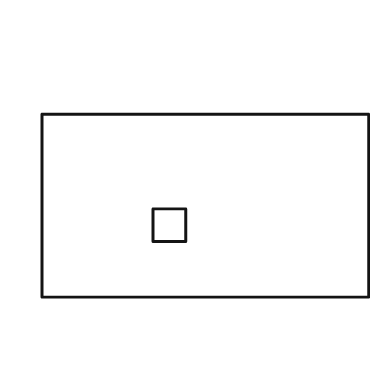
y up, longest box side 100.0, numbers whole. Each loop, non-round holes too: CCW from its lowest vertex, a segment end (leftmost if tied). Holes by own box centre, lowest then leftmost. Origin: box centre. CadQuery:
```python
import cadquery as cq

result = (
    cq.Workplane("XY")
    .moveTo(-50.0, -28.0)
    .lineTo(50.0, -28.0)
    .lineTo(50.0, 28.0)
    .lineTo(-50.0, 28.0)
    .close()
    .moveTo(-16.0, -11.0)
    .lineTo(-6.0, -11.0)
    .lineTo(-6.0, -1.0)
    .lineTo(-16.0, -1.0)
    .close()
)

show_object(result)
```